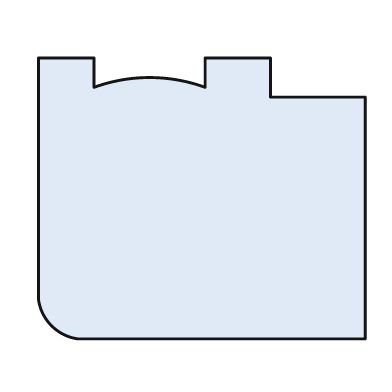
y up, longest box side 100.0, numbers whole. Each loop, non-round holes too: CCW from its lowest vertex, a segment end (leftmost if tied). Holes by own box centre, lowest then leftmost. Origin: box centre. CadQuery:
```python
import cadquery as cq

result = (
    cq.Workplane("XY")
    .moveTo(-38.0, -43.0)
    .lineTo(50.0, -43.0)
    .lineTo(50.0, 31.0)
    .lineTo(21.0, 31.0)
    .lineTo(21.0, 43.0)
    .lineTo(1.0, 43.0)
    .lineTo(1.0, 34.0)
    .threePointArc((-16.0, 37.0), (-33.0, 34.0))
    .lineTo(-33.0, 43.0)
    .lineTo(-50.0, 43.0)
    .lineTo(-50.0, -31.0)
    .threePointArc((-46.0, -39.0), (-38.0, -43.0))
    .close()
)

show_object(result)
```